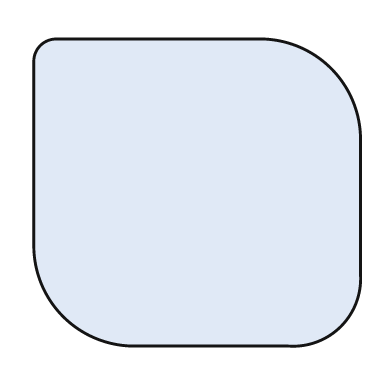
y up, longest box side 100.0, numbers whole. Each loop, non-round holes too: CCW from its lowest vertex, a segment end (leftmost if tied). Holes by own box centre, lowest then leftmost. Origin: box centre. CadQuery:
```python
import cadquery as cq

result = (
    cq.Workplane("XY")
    .moveTo(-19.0, -47.0)
    .lineTo(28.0, -47.0)
    .threePointArc((44.0, -41.0), (50.0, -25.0))
    .lineTo(50.0, 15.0)
    .threePointArc((41.0, 38.0), (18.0, 47.0))
    .lineTo(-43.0, 47.0)
    .threePointArc((-48.0, 45.0), (-50.0, 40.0))
    .lineTo(-50.0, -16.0)
    .threePointArc((-41.0, -38.0), (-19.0, -47.0))
    .close()
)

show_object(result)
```